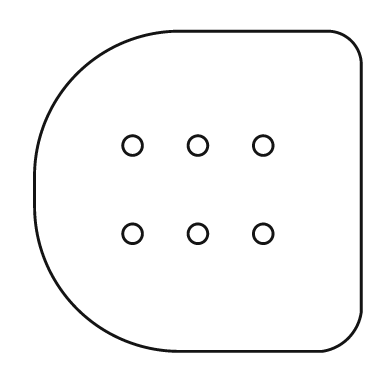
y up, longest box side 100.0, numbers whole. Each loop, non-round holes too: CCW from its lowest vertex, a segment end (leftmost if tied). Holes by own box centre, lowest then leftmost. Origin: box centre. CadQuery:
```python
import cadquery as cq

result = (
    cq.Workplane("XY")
    .moveTo(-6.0, -49.0)
    .lineTo(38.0, -49.0)
    .threePointArc((46.0, -45.0), (50.0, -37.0))
    .lineTo(50.0, 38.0)
    .threePointArc((47.0, 46.0), (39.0, 49.0))
    .lineTo(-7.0, 49.0)
    .threePointArc((-37.0, 36.0), (-50.0, 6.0))
    .lineTo(-50.0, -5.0)
    .threePointArc((-37.0, -36.0), (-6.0, -49.0))
    .close()
    .moveTo(-20.0, -13.0)
    .circle(3.0)
    .moveTo(0.0, -13.0)
    .circle(3.0)
    .moveTo(20.0, -13.0)
    .circle(3.0)
    .moveTo(-20.0, 14.0)
    .circle(3.0)
    .moveTo(0.0, 14.0)
    .circle(3.0)
    .moveTo(20.0, 14.0)
    .circle(3.0)
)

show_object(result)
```